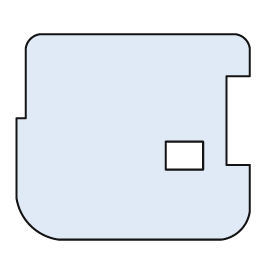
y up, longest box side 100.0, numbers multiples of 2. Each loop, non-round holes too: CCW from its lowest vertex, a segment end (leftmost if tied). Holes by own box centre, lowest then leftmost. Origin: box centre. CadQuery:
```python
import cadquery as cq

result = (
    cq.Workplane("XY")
    .moveTo(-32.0, -44.0)
    .lineTo(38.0, -44.0)
    .threePointArc((46.0, -40.0), (50.0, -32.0))
    .lineTo(50.0, -12.0)
    .lineTo(40.0, -12.0)
    .lineTo(40.0, 26.0)
    .lineTo(50.0, 26.0)
    .lineTo(50.0, 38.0)
    .threePointArc((48.0, 42.0), (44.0, 44.0))
    .lineTo(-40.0, 44.0)
    .threePointArc((-44.0, 42.0), (-46.0, 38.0))
    .lineTo(-46.0, 8.0)
    .lineTo(-50.0, 8.0)
    .lineTo(-50.0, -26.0)
    .threePointArc((-44.0, -38.0), (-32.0, -44.0))
    .close()
    .moveTo(14.0, -14.0)
    .lineTo(30.0, -14.0)
    .lineTo(30.0, -2.0)
    .lineTo(14.0, -2.0)
    .close()
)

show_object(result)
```